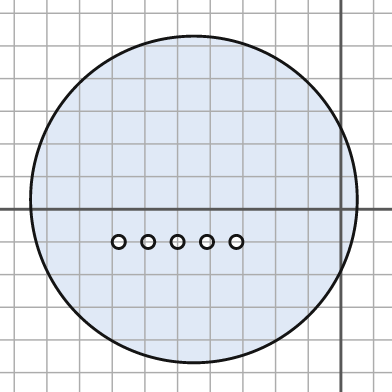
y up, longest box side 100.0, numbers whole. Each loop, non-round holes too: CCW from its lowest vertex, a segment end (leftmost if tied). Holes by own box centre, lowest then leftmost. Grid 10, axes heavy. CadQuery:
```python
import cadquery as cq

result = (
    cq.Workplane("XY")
    .moveTo(-45.0, 3.0)
    .circle(50.0)
    .moveTo(-68.0, -10.0)
    .circle(2.0)
    .moveTo(-59.0, -10.0)
    .circle(2.0)
    .moveTo(-50.0, -10.0)
    .circle(2.0)
    .moveTo(-41.0, -10.0)
    .circle(2.0)
    .moveTo(-32.0, -10.0)
    .circle(2.0)
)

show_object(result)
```